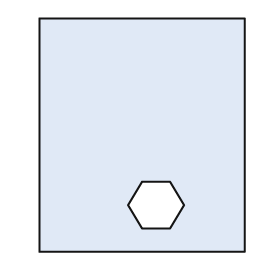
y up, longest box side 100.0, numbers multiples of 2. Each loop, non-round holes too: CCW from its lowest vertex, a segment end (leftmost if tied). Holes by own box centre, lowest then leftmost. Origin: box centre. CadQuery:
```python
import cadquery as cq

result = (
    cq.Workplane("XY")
    .moveTo(-44.0, -50.0)
    .lineTo(44.0, -50.0)
    .lineTo(44.0, 50.0)
    .lineTo(-44.0, 50.0)
    .close()
    .moveTo(0.0, -40.0)
    .lineTo(12.0, -40.0)
    .lineTo(18.0, -30.0)
    .lineTo(12.0, -20.0)
    .lineTo(0.0, -20.0)
    .lineTo(-6.0, -30.0)
    .close()
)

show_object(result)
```